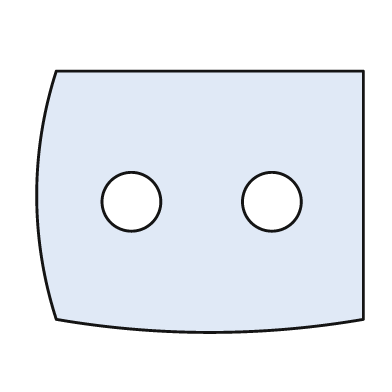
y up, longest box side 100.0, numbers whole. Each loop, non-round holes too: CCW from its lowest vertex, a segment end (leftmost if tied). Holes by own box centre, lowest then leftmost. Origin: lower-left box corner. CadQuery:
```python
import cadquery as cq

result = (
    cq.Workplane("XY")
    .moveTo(6.0, 4.0)
    .threePointArc((53.0, 0.0), (100.0, 4.0))
    .lineTo(100.0, 80.0)
    .lineTo(6.0, 80.0)
    .threePointArc((0.0, 42.0), (6.0, 4.0))
    .close()
    .moveTo(29.0, 40.0)
    .circle(9.0)
    .moveTo(72.0, 40.0)
    .circle(9.0)
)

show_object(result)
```